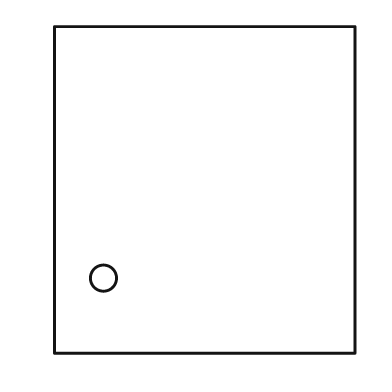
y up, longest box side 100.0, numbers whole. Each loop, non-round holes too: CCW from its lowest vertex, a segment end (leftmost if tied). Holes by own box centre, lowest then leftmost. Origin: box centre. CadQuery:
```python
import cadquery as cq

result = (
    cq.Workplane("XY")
    .moveTo(-46.0, -50.0)
    .lineTo(46.0, -50.0)
    .lineTo(46.0, 50.0)
    .lineTo(-46.0, 50.0)
    .close()
    .moveTo(-31.0, -27.0)
    .circle(4.0)
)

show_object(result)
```